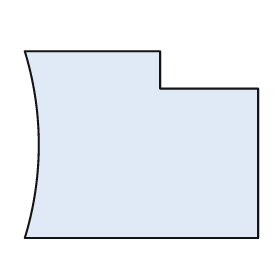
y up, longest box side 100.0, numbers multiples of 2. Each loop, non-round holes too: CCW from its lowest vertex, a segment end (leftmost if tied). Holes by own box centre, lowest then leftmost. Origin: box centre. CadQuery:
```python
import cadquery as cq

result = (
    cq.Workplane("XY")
    .moveTo(-50.0, -40.0)
    .lineTo(50.0, -40.0)
    .lineTo(50.0, 24.0)
    .lineTo(8.0, 24.0)
    .lineTo(8.0, 40.0)
    .lineTo(-50.0, 40.0)
    .threePointArc((-44.0, 0.0), (-50.0, -40.0))
    .close()
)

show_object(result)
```